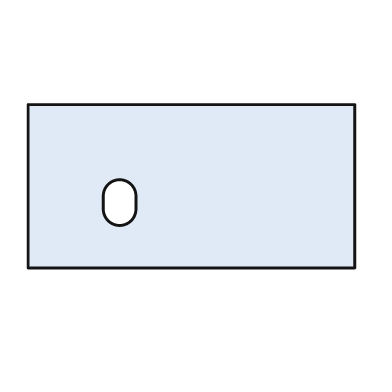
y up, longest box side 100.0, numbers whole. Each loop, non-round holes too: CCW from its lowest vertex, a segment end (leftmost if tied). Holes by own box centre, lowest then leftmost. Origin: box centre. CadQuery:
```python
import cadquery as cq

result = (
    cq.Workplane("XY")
    .moveTo(-50.0, -25.0)
    .lineTo(50.0, -25.0)
    .lineTo(50.0, 25.0)
    .lineTo(-50.0, 25.0)
    .close()
    .moveTo(-27.0, -7.0)
    .threePointArc((-22.0, -12.0), (-17.0, -7.0))
    .lineTo(-17.0, -3.0)
    .threePointArc((-22.0, 2.0), (-27.0, -3.0))
    .close()
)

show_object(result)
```